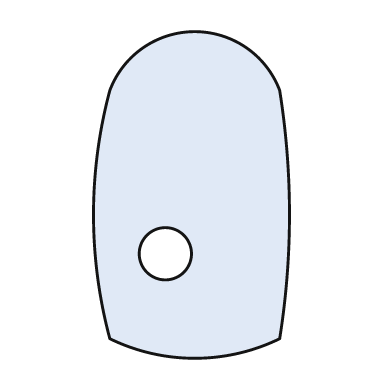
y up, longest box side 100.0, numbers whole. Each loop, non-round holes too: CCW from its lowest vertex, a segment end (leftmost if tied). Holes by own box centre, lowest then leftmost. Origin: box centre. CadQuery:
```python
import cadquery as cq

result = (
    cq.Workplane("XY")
    .moveTo(-25.0, -44.0)
    .threePointArc((1.0, -50.0), (27.0, -44.0))
    .threePointArc((30.0, -6.0), (27.0, 32.0))
    .threePointArc((1.0, 50.0), (-25.0, 32.0))
    .threePointArc((-30.0, -6.0), (-25.0, -44.0))
    .close()
    .moveTo(-8.0, -18.0)
    .circle(8.0)
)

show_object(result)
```